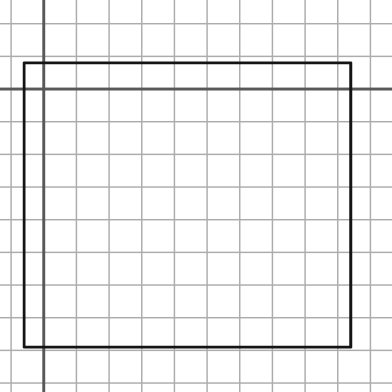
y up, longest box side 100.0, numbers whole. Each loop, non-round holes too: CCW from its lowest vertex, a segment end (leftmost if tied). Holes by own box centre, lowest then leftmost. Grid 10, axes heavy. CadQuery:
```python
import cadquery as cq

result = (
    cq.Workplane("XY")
    .moveTo(-6.0, -79.0)
    .lineTo(94.0, -79.0)
    .lineTo(94.0, 8.0)
    .lineTo(-6.0, 8.0)
    .close()
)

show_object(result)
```